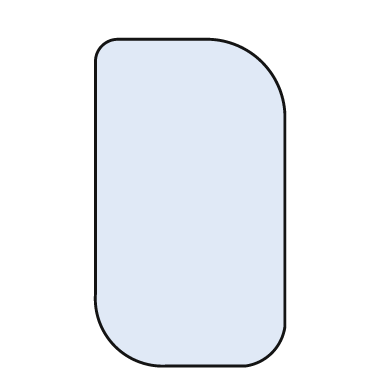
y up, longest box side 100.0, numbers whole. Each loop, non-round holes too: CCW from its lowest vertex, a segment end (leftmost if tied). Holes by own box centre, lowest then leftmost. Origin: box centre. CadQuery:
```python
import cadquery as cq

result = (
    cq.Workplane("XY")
    .moveTo(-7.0, -50.0)
    .lineTo(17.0, -50.0)
    .threePointArc((25.0, -46.0), (29.0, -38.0))
    .lineTo(29.0, 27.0)
    .threePointArc((22.0, 43.0), (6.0, 50.0))
    .lineTo(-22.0, 50.0)
    .threePointArc((-27.0, 48.0), (-29.0, 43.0))
    .lineTo(-29.0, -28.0)
    .threePointArc((-23.0, -44.0), (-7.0, -50.0))
    .close()
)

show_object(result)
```